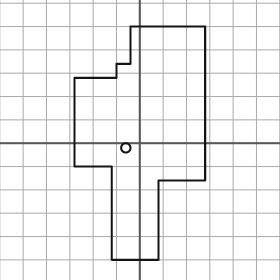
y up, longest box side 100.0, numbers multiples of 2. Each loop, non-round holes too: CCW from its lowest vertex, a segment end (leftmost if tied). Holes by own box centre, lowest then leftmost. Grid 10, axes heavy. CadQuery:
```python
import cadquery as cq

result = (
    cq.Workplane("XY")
    .moveTo(-12.0, -50.0)
    .lineTo(8.0, -50.0)
    .lineTo(8.0, -16.0)
    .lineTo(28.0, -16.0)
    .lineTo(28.0, 50.0)
    .lineTo(-4.0, 50.0)
    .lineTo(-4.0, 34.0)
    .lineTo(-10.0, 34.0)
    .lineTo(-10.0, 28.0)
    .lineTo(-28.0, 28.0)
    .lineTo(-28.0, -10.0)
    .lineTo(-12.0, -10.0)
    .close()
    .moveTo(-6.0, -2.0)
    .circle(2.0)
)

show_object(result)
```